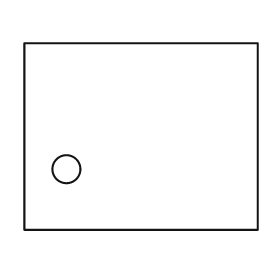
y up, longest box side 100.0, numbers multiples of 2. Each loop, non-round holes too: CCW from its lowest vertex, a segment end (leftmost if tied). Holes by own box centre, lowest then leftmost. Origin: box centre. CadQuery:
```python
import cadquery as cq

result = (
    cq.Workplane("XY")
    .moveTo(-50.0, -40.0)
    .lineTo(50.0, -40.0)
    .lineTo(50.0, 40.0)
    .lineTo(-50.0, 40.0)
    .close()
    .moveTo(-32.0, -14.0)
    .circle(6.0)
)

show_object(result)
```